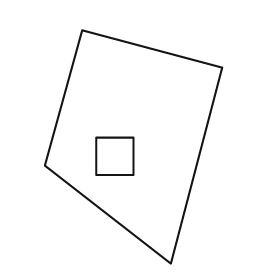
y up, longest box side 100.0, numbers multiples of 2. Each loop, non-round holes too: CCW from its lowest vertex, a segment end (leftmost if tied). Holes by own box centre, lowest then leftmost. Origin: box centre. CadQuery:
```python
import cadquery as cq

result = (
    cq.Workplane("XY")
    .moveTo(16.0, -50.0)
    .lineTo(38.0, 34.0)
    .lineTo(-22.0, 50.0)
    .lineTo(-38.0, -8.0)
    .close()
    .moveTo(-16.0, -12.0)
    .lineTo(0.0, -12.0)
    .lineTo(0.0, 4.0)
    .lineTo(-16.0, 4.0)
    .close()
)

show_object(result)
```